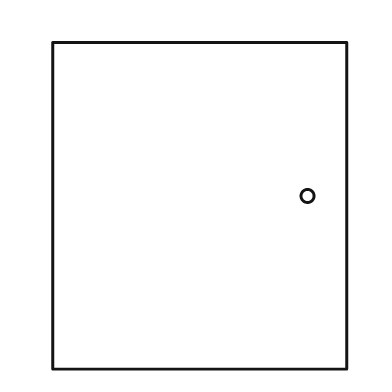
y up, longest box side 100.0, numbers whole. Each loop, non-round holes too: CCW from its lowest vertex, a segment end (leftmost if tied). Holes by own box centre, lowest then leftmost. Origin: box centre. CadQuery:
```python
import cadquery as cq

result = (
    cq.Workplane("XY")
    .moveTo(-45.0, -50.0)
    .lineTo(45.0, -50.0)
    .lineTo(45.0, 50.0)
    .lineTo(-45.0, 50.0)
    .close()
    .moveTo(33.0, 3.0)
    .circle(2.0)
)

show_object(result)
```